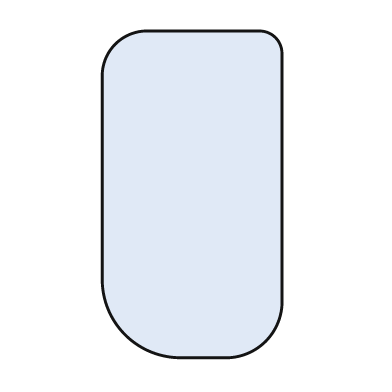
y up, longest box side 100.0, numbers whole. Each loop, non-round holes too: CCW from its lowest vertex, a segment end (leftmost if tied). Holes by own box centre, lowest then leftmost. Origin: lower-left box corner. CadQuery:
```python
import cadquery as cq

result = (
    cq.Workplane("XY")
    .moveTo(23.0, 0.0)
    .lineTo(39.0, 0.0)
    .threePointArc((50.0, 5.0), (55.0, 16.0))
    .lineTo(55.0, 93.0)
    .threePointArc((53.0, 98.0), (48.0, 100.0))
    .lineTo(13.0, 100.0)
    .threePointArc((4.0, 96.0), (0.0, 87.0))
    .lineTo(0.0, 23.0)
    .threePointArc((7.0, 7.0), (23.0, 0.0))
    .close()
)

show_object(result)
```